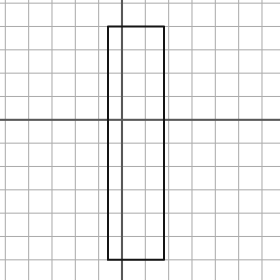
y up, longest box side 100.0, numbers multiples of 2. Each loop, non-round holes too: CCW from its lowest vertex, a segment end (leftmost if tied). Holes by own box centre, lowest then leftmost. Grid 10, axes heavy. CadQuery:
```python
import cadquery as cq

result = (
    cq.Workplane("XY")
    .moveTo(-6.0, -60.0)
    .lineTo(18.0, -60.0)
    .lineTo(18.0, 40.0)
    .lineTo(-6.0, 40.0)
    .close()
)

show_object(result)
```